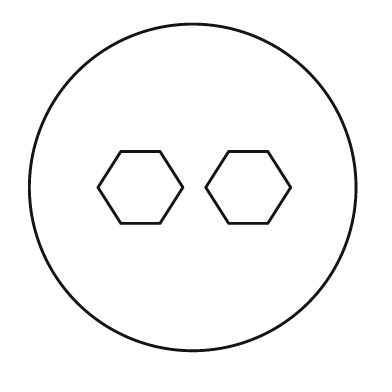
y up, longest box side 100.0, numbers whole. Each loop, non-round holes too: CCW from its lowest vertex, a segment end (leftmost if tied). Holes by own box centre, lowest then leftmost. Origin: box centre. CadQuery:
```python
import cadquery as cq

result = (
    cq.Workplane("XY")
    .moveTo(0.0, 0.0)
    .circle(50.0)
    .moveTo(-22.0, -11.0)
    .lineTo(-10.0, -11.0)
    .lineTo(-3.0, 0.0)
    .lineTo(-10.0, 11.0)
    .lineTo(-22.0, 11.0)
    .lineTo(-29.0, 0.0)
    .close()
    .moveTo(11.0, -11.0)
    .lineTo(23.0, -11.0)
    .lineTo(30.0, 0.0)
    .lineTo(23.0, 11.0)
    .lineTo(11.0, 11.0)
    .lineTo(4.0, 0.0)
    .close()
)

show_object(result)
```